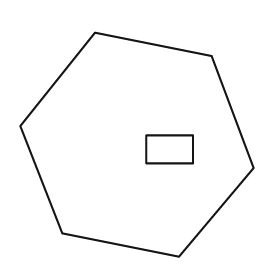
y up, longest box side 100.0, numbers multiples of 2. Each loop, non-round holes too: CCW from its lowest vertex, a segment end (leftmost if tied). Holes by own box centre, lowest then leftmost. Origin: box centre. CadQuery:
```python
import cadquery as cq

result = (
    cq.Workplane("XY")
    .moveTo(18.0, -48.0)
    .lineTo(50.0, -10.0)
    .lineTo(32.0, 38.0)
    .lineTo(-18.0, 48.0)
    .lineTo(-50.0, 8.0)
    .lineTo(-32.0, -38.0)
    .close()
    .moveTo(4.0, -8.0)
    .lineTo(24.0, -8.0)
    .lineTo(24.0, 4.0)
    .lineTo(4.0, 4.0)
    .close()
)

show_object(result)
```